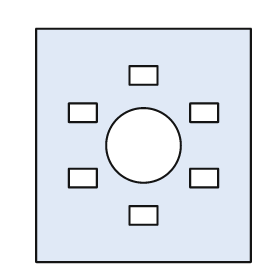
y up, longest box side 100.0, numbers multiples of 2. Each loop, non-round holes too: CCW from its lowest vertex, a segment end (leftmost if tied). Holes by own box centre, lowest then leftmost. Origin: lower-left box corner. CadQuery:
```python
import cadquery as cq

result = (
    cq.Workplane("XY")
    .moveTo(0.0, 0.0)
    .lineTo(92.0, 0.0)
    .lineTo(92.0, 100.0)
    .lineTo(0.0, 100.0)
    .close()
    .moveTo(40.0, 16.0)
    .lineTo(52.0, 16.0)
    .lineTo(52.0, 24.0)
    .lineTo(40.0, 24.0)
    .close()
    .moveTo(14.0, 32.0)
    .lineTo(26.0, 32.0)
    .lineTo(26.0, 40.0)
    .lineTo(14.0, 40.0)
    .close()
    .moveTo(66.0, 32.0)
    .lineTo(78.0, 32.0)
    .lineTo(78.0, 40.0)
    .lineTo(66.0, 40.0)
    .close()
    .moveTo(46.0, 50.0)
    .circle(16.0)
    .moveTo(14.0, 60.0)
    .lineTo(26.0, 60.0)
    .lineTo(26.0, 68.0)
    .lineTo(14.0, 68.0)
    .close()
    .moveTo(66.0, 60.0)
    .lineTo(78.0, 60.0)
    .lineTo(78.0, 68.0)
    .lineTo(66.0, 68.0)
    .close()
    .moveTo(40.0, 76.0)
    .lineTo(52.0, 76.0)
    .lineTo(52.0, 84.0)
    .lineTo(40.0, 84.0)
    .close()
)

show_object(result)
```